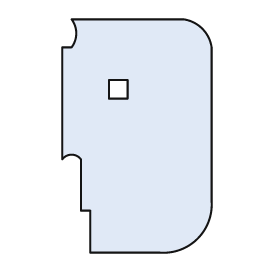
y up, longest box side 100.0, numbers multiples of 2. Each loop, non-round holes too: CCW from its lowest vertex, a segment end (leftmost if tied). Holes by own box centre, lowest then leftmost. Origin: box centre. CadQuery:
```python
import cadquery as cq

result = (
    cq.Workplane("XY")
    .moveTo(-20.0, -50.0)
    .lineTo(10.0, -50.0)
    .threePointArc((26.0, -44.0), (32.0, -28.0))
    .lineTo(32.0, 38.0)
    .threePointArc((28.0, 46.0), (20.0, 50.0))
    .lineTo(-28.0, 50.0)
    .threePointArc((-26.0, 44.0), (-28.0, 38.0))
    .lineTo(-32.0, 38.0)
    .lineTo(-32.0, -10.0)
    .threePointArc((-28.0, -8.0), (-24.0, -10.0))
    .lineTo(-24.0, -32.0)
    .lineTo(-20.0, -32.0)
    .close()
    .moveTo(-12.0, 16.0)
    .lineTo(-4.0, 16.0)
    .lineTo(-4.0, 24.0)
    .lineTo(-12.0, 24.0)
    .close()
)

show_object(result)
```